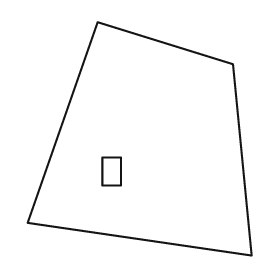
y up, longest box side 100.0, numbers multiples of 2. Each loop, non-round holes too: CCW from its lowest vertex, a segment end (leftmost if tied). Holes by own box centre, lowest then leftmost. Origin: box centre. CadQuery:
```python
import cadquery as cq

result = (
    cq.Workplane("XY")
    .moveTo(48.0, -50.0)
    .lineTo(40.0, 32.0)
    .lineTo(-18.0, 50.0)
    .lineTo(-48.0, -36.0)
    .close()
    .moveTo(-16.0, -20.0)
    .lineTo(-8.0, -20.0)
    .lineTo(-8.0, -8.0)
    .lineTo(-16.0, -8.0)
    .close()
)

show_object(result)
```